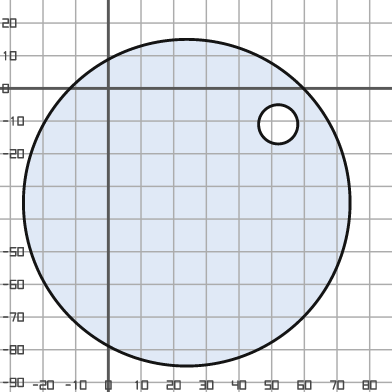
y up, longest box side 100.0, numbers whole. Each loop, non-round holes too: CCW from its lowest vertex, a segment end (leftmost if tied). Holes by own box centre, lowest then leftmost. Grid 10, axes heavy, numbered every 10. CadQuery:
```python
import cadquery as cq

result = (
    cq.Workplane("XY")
    .moveTo(24.0, -35.0)
    .circle(50.0)
    .moveTo(52.0, -11.0)
    .circle(6.0)
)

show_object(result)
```